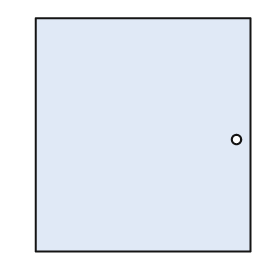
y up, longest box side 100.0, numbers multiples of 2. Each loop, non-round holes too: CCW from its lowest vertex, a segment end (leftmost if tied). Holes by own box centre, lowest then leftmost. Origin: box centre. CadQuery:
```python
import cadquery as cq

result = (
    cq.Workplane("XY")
    .moveTo(-46.0, -50.0)
    .lineTo(46.0, -50.0)
    .lineTo(46.0, 50.0)
    .lineTo(-46.0, 50.0)
    .close()
    .moveTo(40.0, -2.0)
    .circle(2.0)
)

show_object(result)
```